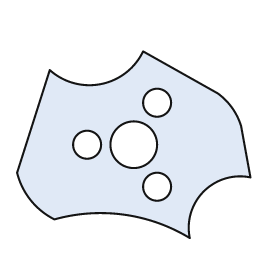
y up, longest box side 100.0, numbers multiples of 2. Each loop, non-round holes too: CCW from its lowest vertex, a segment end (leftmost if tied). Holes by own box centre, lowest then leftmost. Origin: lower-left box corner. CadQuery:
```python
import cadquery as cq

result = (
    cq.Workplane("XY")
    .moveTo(74.0, 0.0)
    .threePointArc((80.0, 20.0), (100.0, 26.0))
    .lineTo(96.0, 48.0)
    .threePointArc((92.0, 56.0), (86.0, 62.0))
    .lineTo(54.0, 80.0)
    .threePointArc((36.0, 66.0), (14.0, 72.0))
    .lineTo(0.0, 28.0)
    .threePointArc((6.0, 16.0), (16.0, 8.0))
    .threePointArc((46.0, 10.0), (74.0, 0.0))
    .close()
    .moveTo(60.0, 22.0)
    .circle(6.0)
    .moveTo(30.0, 40.0)
    .circle(6.0)
    .moveTo(50.0, 40.0)
    .circle(10.0)
    .moveTo(60.0, 58.0)
    .circle(6.0)
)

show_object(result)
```